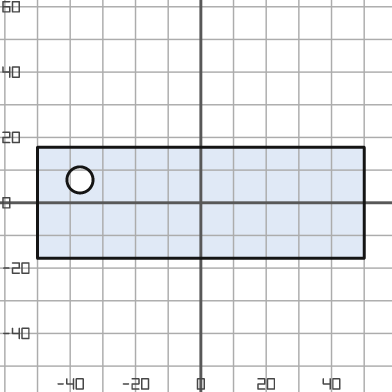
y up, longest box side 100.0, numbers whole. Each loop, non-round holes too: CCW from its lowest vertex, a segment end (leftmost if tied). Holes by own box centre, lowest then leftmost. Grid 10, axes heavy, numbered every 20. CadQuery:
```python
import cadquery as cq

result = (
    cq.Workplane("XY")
    .moveTo(-50.0, -17.0)
    .lineTo(50.0, -17.0)
    .lineTo(50.0, 17.0)
    .lineTo(-50.0, 17.0)
    .close()
    .moveTo(-37.0, 7.0)
    .circle(4.0)
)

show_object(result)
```